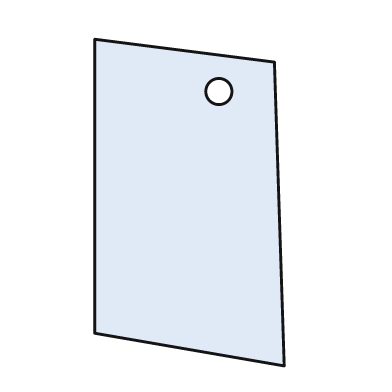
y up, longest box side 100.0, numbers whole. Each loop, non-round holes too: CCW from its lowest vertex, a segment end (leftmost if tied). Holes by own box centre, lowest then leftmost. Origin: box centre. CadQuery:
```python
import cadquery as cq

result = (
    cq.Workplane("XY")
    .moveTo(29.0, -50.0)
    .lineTo(26.0, 43.0)
    .lineTo(-29.0, 50.0)
    .lineTo(-29.0, -40.0)
    .close()
    .moveTo(9.0, 34.0)
    .circle(4.0)
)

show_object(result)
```